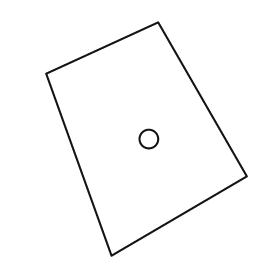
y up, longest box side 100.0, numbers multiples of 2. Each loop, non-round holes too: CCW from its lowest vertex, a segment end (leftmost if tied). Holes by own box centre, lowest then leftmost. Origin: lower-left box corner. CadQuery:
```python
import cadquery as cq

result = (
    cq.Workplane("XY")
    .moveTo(28.0, 0.0)
    .lineTo(86.0, 34.0)
    .lineTo(48.0, 100.0)
    .lineTo(0.0, 78.0)
    .close()
    .moveTo(44.0, 50.0)
    .circle(4.0)
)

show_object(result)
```